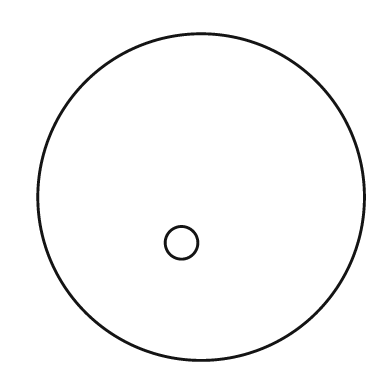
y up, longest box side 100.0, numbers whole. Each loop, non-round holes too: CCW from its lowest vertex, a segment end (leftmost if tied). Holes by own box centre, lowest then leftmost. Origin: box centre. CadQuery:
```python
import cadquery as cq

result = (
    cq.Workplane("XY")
    .moveTo(0.0, 0.0)
    .circle(50.0)
    .moveTo(-6.0, -14.0)
    .circle(5.0)
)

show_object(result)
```